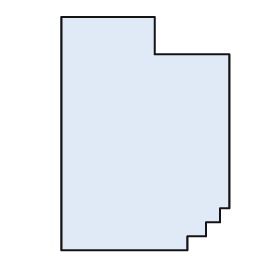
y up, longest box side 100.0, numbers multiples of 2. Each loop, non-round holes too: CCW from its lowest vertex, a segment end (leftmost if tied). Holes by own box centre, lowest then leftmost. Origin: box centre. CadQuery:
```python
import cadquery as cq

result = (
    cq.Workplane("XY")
    .moveTo(-36.0, -50.0)
    .lineTo(18.0, -50.0)
    .lineTo(18.0, -44.0)
    .lineTo(26.0, -44.0)
    .lineTo(26.0, -38.0)
    .lineTo(32.0, -38.0)
    .lineTo(32.0, -32.0)
    .lineTo(36.0, -32.0)
    .lineTo(36.0, 34.0)
    .lineTo(4.0, 34.0)
    .lineTo(4.0, 50.0)
    .lineTo(-36.0, 50.0)
    .close()
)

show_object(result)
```